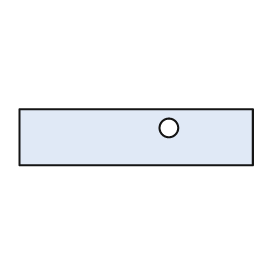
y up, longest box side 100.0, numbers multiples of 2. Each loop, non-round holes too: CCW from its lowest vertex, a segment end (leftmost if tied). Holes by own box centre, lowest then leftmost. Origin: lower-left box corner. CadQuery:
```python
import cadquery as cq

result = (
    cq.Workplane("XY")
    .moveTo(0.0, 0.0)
    .lineTo(100.0, 0.0)
    .lineTo(100.0, 24.0)
    .lineTo(0.0, 24.0)
    .close()
    .moveTo(64.0, 16.0)
    .circle(4.0)
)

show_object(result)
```